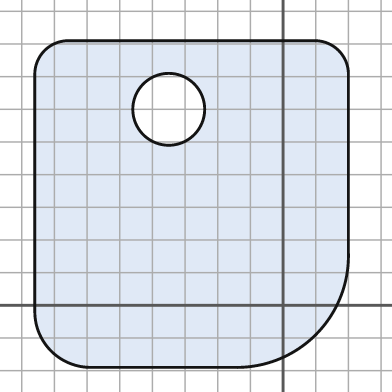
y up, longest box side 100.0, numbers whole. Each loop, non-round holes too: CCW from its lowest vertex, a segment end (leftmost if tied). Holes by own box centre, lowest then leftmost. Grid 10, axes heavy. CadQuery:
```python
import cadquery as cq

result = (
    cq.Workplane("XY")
    .moveTo(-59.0, -19.0)
    .lineTo(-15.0, -19.0)
    .threePointArc((10.0, -9.0), (20.0, 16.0))
    .lineTo(20.0, 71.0)
    .threePointArc((17.0, 78.0), (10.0, 81.0))
    .lineTo(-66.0, 81.0)
    .threePointArc((-73.0, 78.0), (-76.0, 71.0))
    .lineTo(-76.0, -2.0)
    .threePointArc((-71.0, -14.0), (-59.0, -19.0))
    .close()
    .moveTo(-35.0, 60.0)
    .circle(11.0)
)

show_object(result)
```